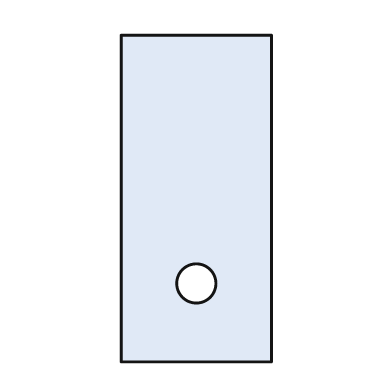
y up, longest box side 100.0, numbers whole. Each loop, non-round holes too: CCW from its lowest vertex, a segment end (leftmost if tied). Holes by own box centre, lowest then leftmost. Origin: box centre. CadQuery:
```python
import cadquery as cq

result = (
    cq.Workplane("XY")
    .moveTo(-23.0, -50.0)
    .lineTo(23.0, -50.0)
    .lineTo(23.0, 50.0)
    .lineTo(-23.0, 50.0)
    .close()
    .moveTo(0.0, -26.0)
    .circle(6.0)
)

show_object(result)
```